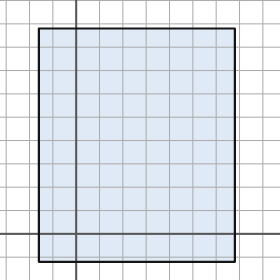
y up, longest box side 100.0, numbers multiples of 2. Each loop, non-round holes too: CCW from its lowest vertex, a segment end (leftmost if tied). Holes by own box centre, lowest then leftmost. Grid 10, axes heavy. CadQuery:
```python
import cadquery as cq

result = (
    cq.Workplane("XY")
    .moveTo(-16.0, -12.0)
    .lineTo(68.0, -12.0)
    .lineTo(68.0, 88.0)
    .lineTo(-16.0, 88.0)
    .close()
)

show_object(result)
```